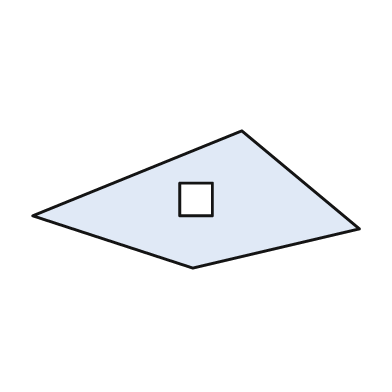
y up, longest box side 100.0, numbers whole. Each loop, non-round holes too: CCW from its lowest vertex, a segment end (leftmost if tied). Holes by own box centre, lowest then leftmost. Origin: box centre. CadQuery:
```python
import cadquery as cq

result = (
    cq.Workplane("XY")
    .moveTo(-1.0, -21.0)
    .lineTo(50.0, -9.0)
    .lineTo(14.0, 21.0)
    .lineTo(-50.0, -5.0)
    .close()
    .moveTo(-5.0, -5.0)
    .lineTo(5.0, -5.0)
    .lineTo(5.0, 5.0)
    .lineTo(-5.0, 5.0)
    .close()
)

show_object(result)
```